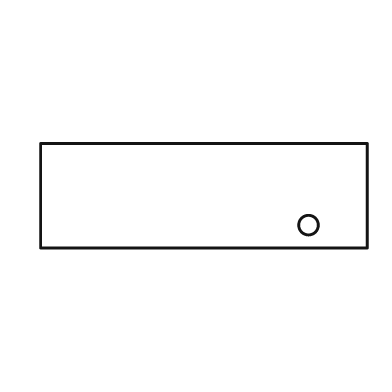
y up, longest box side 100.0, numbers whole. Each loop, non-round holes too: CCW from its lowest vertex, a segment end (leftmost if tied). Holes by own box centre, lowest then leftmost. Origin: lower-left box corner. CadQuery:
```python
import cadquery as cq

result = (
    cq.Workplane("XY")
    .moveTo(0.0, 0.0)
    .lineTo(100.0, 0.0)
    .lineTo(100.0, 32.0)
    .lineTo(0.0, 32.0)
    .close()
    .moveTo(82.0, 7.0)
    .circle(3.0)
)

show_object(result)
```